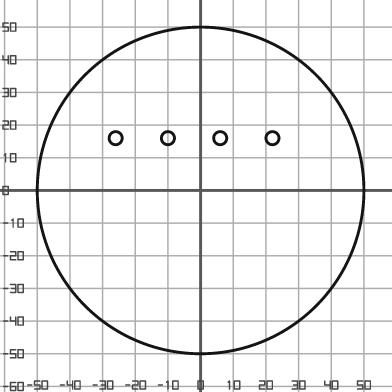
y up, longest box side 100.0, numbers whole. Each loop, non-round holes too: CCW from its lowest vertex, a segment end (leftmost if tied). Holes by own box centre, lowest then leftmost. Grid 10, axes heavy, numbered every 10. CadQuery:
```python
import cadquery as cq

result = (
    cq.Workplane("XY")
    .moveTo(0.0, 0.0)
    .circle(50.0)
    .moveTo(-26.0, 16.0)
    .circle(2.0)
    .moveTo(-10.0, 16.0)
    .circle(2.0)
    .moveTo(6.0, 16.0)
    .circle(2.0)
    .moveTo(22.0, 16.0)
    .circle(2.0)
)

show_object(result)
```